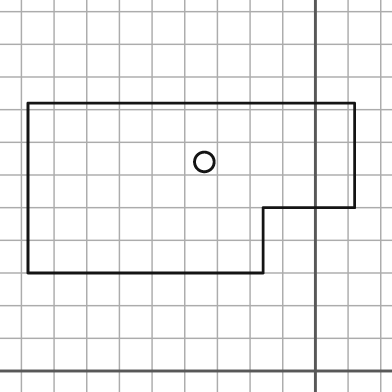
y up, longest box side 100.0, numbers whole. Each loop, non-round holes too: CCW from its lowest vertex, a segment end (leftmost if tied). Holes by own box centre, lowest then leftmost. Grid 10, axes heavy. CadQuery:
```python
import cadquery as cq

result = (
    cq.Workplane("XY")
    .moveTo(-88.0, 30.0)
    .lineTo(-16.0, 30.0)
    .lineTo(-16.0, 50.0)
    .lineTo(12.0, 50.0)
    .lineTo(12.0, 82.0)
    .lineTo(-88.0, 82.0)
    .close()
    .moveTo(-34.0, 64.0)
    .circle(3.0)
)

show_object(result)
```